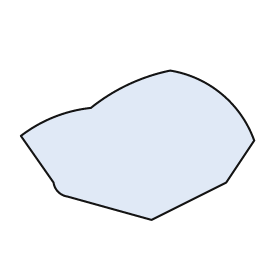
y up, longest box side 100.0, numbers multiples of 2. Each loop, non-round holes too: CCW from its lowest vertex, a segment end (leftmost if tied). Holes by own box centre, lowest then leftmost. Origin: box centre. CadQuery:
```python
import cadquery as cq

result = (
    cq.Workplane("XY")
    .moveTo(6.0, -32.0)
    .lineTo(38.0, -16.0)
    .lineTo(50.0, 2.0)
    .threePointArc((36.0, 22.0), (14.0, 32.0))
    .threePointArc((-4.0, 26.0), (-20.0, 16.0))
    .threePointArc((-36.0, 12.0), (-50.0, 4.0))
    .lineTo(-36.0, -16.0)
    .threePointArc((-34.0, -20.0), (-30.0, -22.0))
    .close()
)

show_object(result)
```